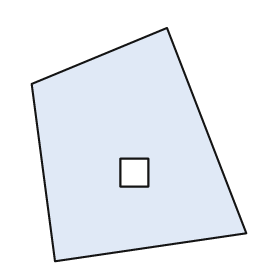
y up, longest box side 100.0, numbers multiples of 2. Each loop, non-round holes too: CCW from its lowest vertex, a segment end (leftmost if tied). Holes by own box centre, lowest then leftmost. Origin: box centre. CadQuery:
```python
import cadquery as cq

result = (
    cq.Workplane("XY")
    .moveTo(-36.0, -50.0)
    .lineTo(46.0, -38.0)
    .lineTo(12.0, 50.0)
    .lineTo(-46.0, 26.0)
    .close()
    .moveTo(-8.0, -18.0)
    .lineTo(4.0, -18.0)
    .lineTo(4.0, -6.0)
    .lineTo(-8.0, -6.0)
    .close()
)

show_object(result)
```